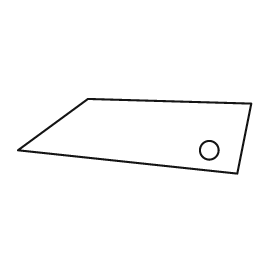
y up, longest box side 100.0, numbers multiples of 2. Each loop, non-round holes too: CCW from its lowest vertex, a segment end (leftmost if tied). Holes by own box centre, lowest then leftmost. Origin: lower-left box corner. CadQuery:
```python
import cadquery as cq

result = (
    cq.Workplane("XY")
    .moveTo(94.0, 0.0)
    .lineTo(100.0, 30.0)
    .lineTo(30.0, 32.0)
    .lineTo(0.0, 10.0)
    .close()
    .moveTo(82.0, 10.0)
    .circle(4.0)
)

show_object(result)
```